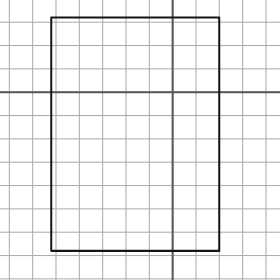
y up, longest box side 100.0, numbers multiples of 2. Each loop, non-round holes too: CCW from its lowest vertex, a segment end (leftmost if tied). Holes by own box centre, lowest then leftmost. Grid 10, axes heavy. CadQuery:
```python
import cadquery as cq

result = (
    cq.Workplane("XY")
    .moveTo(-52.0, -68.0)
    .lineTo(20.0, -68.0)
    .lineTo(20.0, 32.0)
    .lineTo(-52.0, 32.0)
    .close()
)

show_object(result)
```